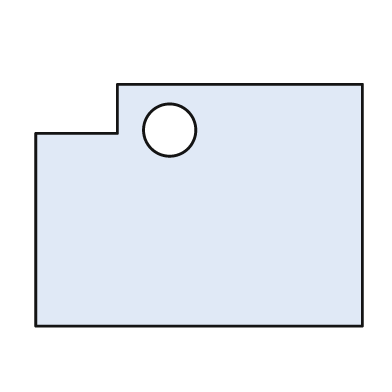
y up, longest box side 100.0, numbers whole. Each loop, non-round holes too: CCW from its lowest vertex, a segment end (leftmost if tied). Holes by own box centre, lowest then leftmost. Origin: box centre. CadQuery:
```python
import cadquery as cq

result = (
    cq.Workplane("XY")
    .moveTo(-50.0, -37.0)
    .lineTo(50.0, -37.0)
    .lineTo(50.0, 37.0)
    .lineTo(-25.0, 37.0)
    .lineTo(-25.0, 22.0)
    .lineTo(-50.0, 22.0)
    .close()
    .moveTo(-9.0, 23.0)
    .circle(8.0)
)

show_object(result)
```